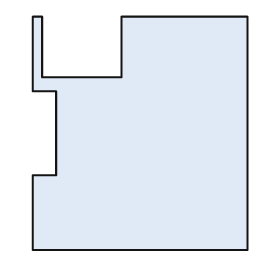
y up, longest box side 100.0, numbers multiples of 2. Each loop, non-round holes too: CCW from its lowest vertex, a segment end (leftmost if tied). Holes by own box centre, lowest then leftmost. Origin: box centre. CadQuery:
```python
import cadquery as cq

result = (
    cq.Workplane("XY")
    .moveTo(-46.0, -50.0)
    .lineTo(46.0, -50.0)
    .lineTo(46.0, 50.0)
    .lineTo(-8.0, 50.0)
    .lineTo(-8.0, 24.0)
    .lineTo(-42.0, 24.0)
    .lineTo(-42.0, 50.0)
    .lineTo(-46.0, 50.0)
    .lineTo(-46.0, 18.0)
    .lineTo(-36.0, 18.0)
    .lineTo(-36.0, -18.0)
    .lineTo(-46.0, -18.0)
    .close()
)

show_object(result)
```